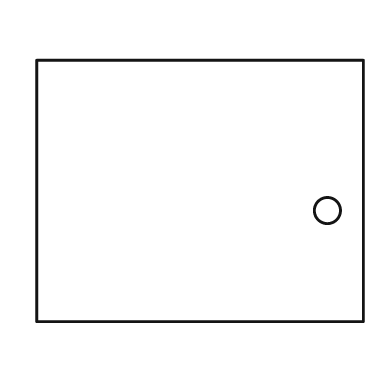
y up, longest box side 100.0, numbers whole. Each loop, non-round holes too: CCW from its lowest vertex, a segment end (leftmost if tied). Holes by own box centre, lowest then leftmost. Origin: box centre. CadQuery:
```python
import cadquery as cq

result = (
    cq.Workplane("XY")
    .moveTo(-50.0, -40.0)
    .lineTo(50.0, -40.0)
    .lineTo(50.0, 40.0)
    .lineTo(-50.0, 40.0)
    .close()
    .moveTo(39.0, -6.0)
    .circle(4.0)
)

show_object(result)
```